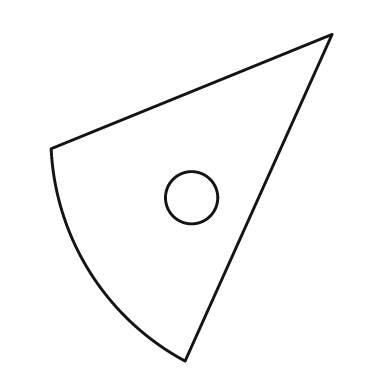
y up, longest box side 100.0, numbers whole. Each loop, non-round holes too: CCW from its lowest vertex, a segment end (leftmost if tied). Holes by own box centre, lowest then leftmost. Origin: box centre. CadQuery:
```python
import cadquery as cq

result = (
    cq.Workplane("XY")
    .moveTo(-2.0, -50.0)
    .lineTo(43.0, 50.0)
    .lineTo(-43.0, 15.0)
    .threePointArc((-31.0, -23.0), (-2.0, -50.0))
    .close()
    .moveTo(0.0, 0.0)
    .circle(8.0)
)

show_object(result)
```